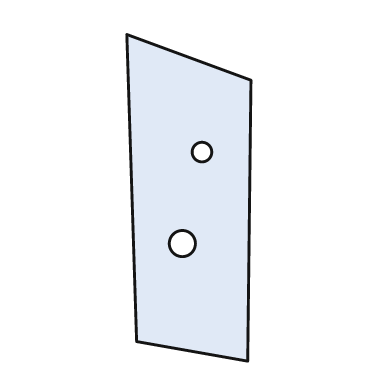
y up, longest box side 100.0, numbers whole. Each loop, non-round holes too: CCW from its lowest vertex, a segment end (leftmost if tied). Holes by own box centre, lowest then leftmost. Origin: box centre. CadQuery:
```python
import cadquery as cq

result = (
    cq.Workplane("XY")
    .moveTo(18.0, -50.0)
    .lineTo(19.0, 36.0)
    .lineTo(-19.0, 50.0)
    .lineTo(-16.0, -44.0)
    .close()
    .moveTo(-2.0, -14.0)
    .circle(4.0)
    .moveTo(4.0, 14.0)
    .circle(3.0)
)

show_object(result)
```